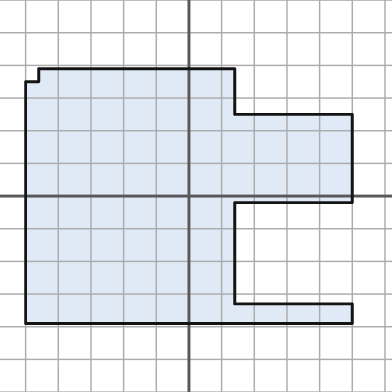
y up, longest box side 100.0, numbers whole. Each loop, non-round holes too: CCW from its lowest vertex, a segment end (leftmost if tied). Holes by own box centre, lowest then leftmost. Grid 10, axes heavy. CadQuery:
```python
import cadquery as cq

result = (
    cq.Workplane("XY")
    .moveTo(-50.0, -39.0)
    .lineTo(50.0, -39.0)
    .lineTo(50.0, -33.0)
    .lineTo(14.0, -33.0)
    .lineTo(14.0, -2.0)
    .lineTo(50.0, -2.0)
    .lineTo(50.0, 25.0)
    .lineTo(14.0, 25.0)
    .lineTo(14.0, 39.0)
    .lineTo(-46.0, 39.0)
    .lineTo(-46.0, 35.0)
    .lineTo(-50.0, 35.0)
    .close()
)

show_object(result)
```